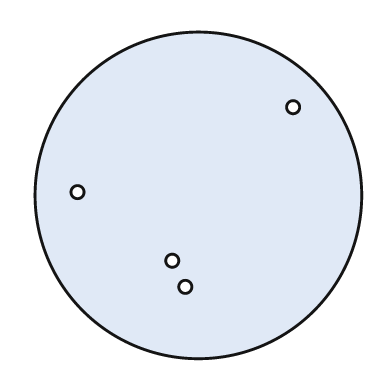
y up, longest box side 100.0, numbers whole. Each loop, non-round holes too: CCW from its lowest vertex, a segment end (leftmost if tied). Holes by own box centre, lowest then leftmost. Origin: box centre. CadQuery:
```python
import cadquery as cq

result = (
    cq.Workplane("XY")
    .moveTo(0.0, 0.0)
    .circle(50.0)
    .moveTo(-4.0, -28.0)
    .circle(2.0)
    .moveTo(-8.0, -20.0)
    .circle(2.0)
    .moveTo(-37.0, 1.0)
    .circle(2.0)
    .moveTo(29.0, 27.0)
    .circle(2.0)
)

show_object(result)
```